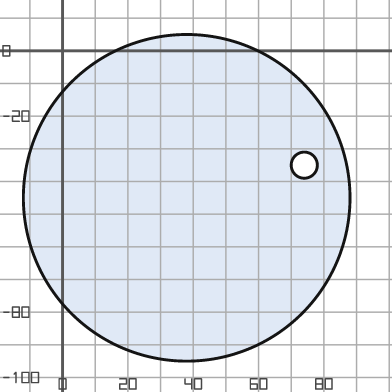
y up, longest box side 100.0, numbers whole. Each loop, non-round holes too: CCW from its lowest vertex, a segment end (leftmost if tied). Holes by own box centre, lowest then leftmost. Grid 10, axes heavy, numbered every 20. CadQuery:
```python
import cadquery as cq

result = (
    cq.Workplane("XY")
    .moveTo(38.0, -45.0)
    .circle(50.0)
    .moveTo(74.0, -35.0)
    .circle(4.0)
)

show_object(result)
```